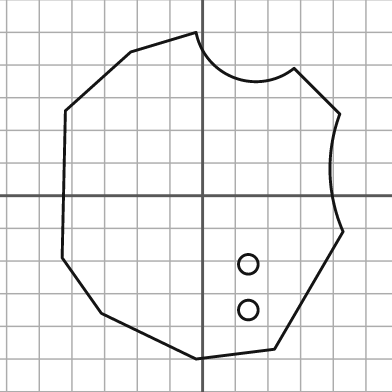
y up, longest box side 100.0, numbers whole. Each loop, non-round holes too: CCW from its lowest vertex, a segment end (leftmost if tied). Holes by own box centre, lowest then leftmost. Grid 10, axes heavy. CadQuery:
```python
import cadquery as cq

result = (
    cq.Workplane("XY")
    .moveTo(-2.0, -50.0)
    .lineTo(22.0, -47.0)
    .lineTo(43.0, -11.0)
    .threePointArc((39.0, 7.0), (42.0, 25.0))
    .lineTo(28.0, 39.0)
    .threePointArc((10.0, 36.0), (-2.0, 50.0))
    .lineTo(-22.0, 44.0)
    .lineTo(-42.0, 26.0)
    .lineTo(-43.0, -19.0)
    .lineTo(-31.0, -36.0)
    .close()
    .moveTo(14.0, -35.0)
    .circle(3.0)
    .moveTo(14.0, -21.0)
    .circle(3.0)
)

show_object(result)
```